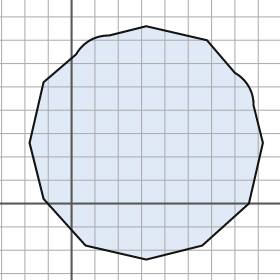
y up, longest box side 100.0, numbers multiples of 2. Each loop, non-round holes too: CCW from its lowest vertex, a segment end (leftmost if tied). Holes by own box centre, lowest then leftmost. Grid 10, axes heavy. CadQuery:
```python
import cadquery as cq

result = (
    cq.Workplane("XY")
    .moveTo(32.0, -24.0)
    .lineTo(56.0, -18.0)
    .lineTo(76.0, 0.0)
    .lineTo(82.0, 26.0)
    .lineTo(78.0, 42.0)
    .threePointArc((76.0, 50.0), (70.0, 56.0))
    .lineTo(58.0, 70.0)
    .lineTo(32.0, 76.0)
    .lineTo(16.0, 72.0)
    .threePointArc((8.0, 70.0), (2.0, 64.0))
    .lineTo(-12.0, 52.0)
    .lineTo(-18.0, 26.0)
    .lineTo(-12.0, 2.0)
    .lineTo(6.0, -18.0)
    .close()
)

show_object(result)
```